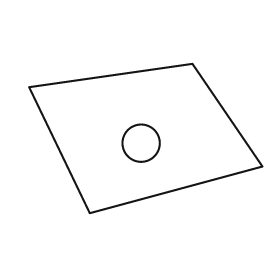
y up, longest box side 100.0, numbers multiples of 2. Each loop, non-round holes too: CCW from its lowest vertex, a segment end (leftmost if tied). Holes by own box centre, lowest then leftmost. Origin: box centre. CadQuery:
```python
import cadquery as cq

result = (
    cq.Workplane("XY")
    .moveTo(-24.0, -32.0)
    .lineTo(50.0, -12.0)
    .lineTo(20.0, 32.0)
    .lineTo(-50.0, 22.0)
    .close()
    .moveTo(-2.0, -2.0)
    .circle(8.0)
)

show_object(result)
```